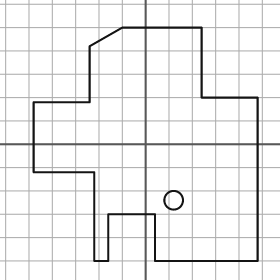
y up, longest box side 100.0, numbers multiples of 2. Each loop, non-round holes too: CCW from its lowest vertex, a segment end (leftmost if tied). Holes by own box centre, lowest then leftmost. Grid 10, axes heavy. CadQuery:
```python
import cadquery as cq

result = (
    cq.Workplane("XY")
    .moveTo(-22.0, -50.0)
    .lineTo(-16.0, -50.0)
    .lineTo(-16.0, -30.0)
    .lineTo(4.0, -30.0)
    .lineTo(4.0, -50.0)
    .lineTo(48.0, -50.0)
    .lineTo(48.0, 20.0)
    .lineTo(24.0, 20.0)
    .lineTo(24.0, 50.0)
    .lineTo(-10.0, 50.0)
    .lineTo(-24.0, 42.0)
    .lineTo(-24.0, 18.0)
    .lineTo(-48.0, 18.0)
    .lineTo(-48.0, -12.0)
    .lineTo(-22.0, -12.0)
    .close()
    .moveTo(12.0, -24.0)
    .circle(4.0)
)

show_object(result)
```